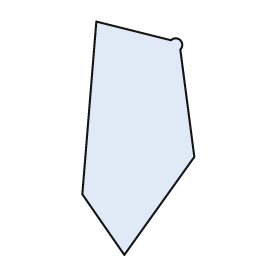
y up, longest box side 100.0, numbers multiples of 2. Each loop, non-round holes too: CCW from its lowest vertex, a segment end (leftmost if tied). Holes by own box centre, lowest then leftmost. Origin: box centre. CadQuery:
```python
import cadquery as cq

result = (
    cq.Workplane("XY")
    .moveTo(-6.0, -50.0)
    .lineTo(24.0, -8.0)
    .lineTo(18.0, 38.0)
    .threePointArc((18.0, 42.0), (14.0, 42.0))
    .lineTo(-18.0, 50.0)
    .lineTo(-24.0, -24.0)
    .close()
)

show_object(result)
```